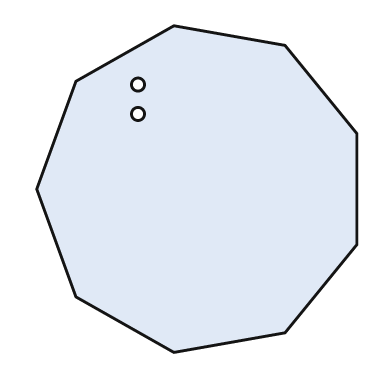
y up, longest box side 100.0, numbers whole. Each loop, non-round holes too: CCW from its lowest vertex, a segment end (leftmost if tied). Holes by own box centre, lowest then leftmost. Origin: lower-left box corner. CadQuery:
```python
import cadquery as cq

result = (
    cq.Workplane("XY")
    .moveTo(42.0, 0.0)
    .lineTo(76.0, 6.0)
    .lineTo(98.0, 33.0)
    .lineTo(98.0, 67.0)
    .lineTo(76.0, 94.0)
    .lineTo(42.0, 100.0)
    .lineTo(12.0, 83.0)
    .lineTo(0.0, 50.0)
    .lineTo(12.0, 17.0)
    .close()
    .moveTo(31.0, 73.0)
    .circle(2.0)
    .moveTo(31.0, 82.0)
    .circle(2.0)
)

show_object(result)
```